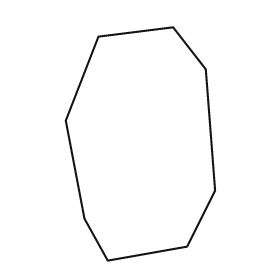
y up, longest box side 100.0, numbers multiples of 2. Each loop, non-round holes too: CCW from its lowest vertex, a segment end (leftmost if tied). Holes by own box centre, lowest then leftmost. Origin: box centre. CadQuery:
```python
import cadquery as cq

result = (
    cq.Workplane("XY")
    .moveTo(-14.0, -50.0)
    .lineTo(20.0, -44.0)
    .lineTo(32.0, -20.0)
    .lineTo(28.0, 32.0)
    .lineTo(14.0, 50.0)
    .lineTo(-18.0, 46.0)
    .lineTo(-32.0, 10.0)
    .lineTo(-24.0, -32.0)
    .close()
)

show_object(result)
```